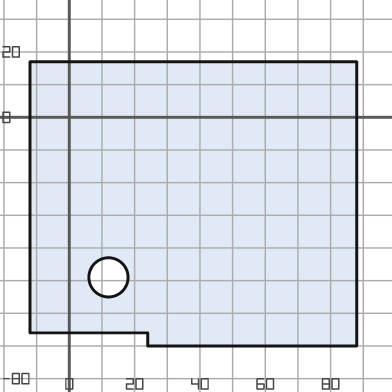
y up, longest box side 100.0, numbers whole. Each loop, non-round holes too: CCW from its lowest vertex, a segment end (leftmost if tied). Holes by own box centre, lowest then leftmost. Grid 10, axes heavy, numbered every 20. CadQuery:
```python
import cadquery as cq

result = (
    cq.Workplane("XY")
    .moveTo(24.0, -70.0)
    .lineTo(88.0, -70.0)
    .lineTo(88.0, 17.0)
    .lineTo(-12.0, 17.0)
    .lineTo(-12.0, -66.0)
    .lineTo(24.0, -66.0)
    .close()
    .moveTo(12.0, -49.0)
    .circle(6.0)
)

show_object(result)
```